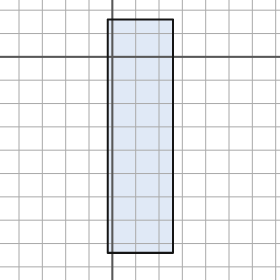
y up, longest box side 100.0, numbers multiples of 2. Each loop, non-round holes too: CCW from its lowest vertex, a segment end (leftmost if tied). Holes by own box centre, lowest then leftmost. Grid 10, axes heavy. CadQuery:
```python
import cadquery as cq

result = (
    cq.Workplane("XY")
    .moveTo(-2.0, -84.0)
    .lineTo(26.0, -84.0)
    .lineTo(26.0, 16.0)
    .lineTo(-2.0, 16.0)
    .close()
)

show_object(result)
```